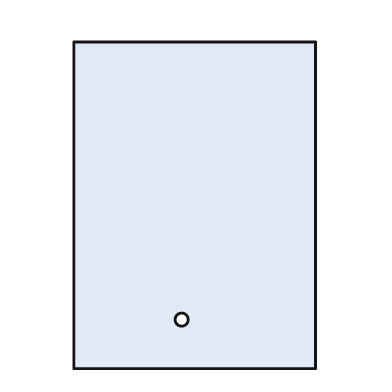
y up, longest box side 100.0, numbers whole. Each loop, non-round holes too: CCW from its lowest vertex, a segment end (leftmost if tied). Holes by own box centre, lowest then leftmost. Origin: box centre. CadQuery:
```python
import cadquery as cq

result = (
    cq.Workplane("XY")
    .moveTo(-37.0, -50.0)
    .lineTo(37.0, -50.0)
    .lineTo(37.0, 50.0)
    .lineTo(-37.0, 50.0)
    .close()
    .moveTo(-4.0, -35.0)
    .circle(2.0)
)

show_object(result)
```